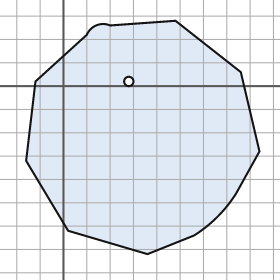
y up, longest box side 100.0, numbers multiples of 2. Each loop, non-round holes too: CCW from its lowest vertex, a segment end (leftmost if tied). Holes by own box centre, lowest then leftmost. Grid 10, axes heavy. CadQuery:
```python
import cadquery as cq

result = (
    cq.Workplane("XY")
    .moveTo(36.0, -72.0)
    .lineTo(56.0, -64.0)
    .threePointArc((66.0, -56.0), (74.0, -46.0))
    .lineTo(84.0, -28.0)
    .lineTo(76.0, 6.0)
    .lineTo(48.0, 28.0)
    .lineTo(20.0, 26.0)
    .threePointArc((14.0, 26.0), (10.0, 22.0))
    .lineTo(-12.0, 2.0)
    .lineTo(-16.0, -32.0)
    .lineTo(2.0, -62.0)
    .close()
    .moveTo(28.0, 2.0)
    .circle(2.0)
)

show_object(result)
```